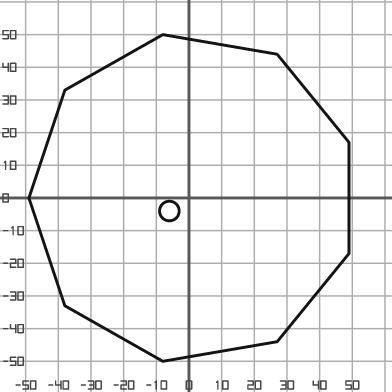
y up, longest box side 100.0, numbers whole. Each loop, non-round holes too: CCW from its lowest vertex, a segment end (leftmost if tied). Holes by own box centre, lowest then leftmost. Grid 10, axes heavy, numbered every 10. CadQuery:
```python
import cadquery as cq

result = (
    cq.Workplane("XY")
    .moveTo(-8.0, -50.0)
    .lineTo(27.0, -44.0)
    .lineTo(49.0, -17.0)
    .lineTo(49.0, 17.0)
    .lineTo(27.0, 44.0)
    .lineTo(-8.0, 50.0)
    .lineTo(-38.0, 33.0)
    .lineTo(-49.0, 0.0)
    .lineTo(-38.0, -33.0)
    .close()
    .moveTo(-6.0, -4.0)
    .circle(3.0)
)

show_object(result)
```